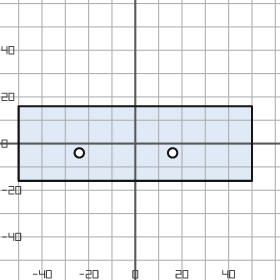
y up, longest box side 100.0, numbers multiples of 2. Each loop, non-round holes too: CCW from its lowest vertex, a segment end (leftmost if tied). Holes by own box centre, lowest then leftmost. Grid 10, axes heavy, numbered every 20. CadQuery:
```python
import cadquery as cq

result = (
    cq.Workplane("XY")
    .moveTo(-50.0, -16.0)
    .lineTo(50.0, -16.0)
    .lineTo(50.0, 16.0)
    .lineTo(-50.0, 16.0)
    .close()
    .moveTo(-24.0, -4.0)
    .circle(2.0)
    .moveTo(16.0, -4.0)
    .circle(2.0)
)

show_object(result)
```